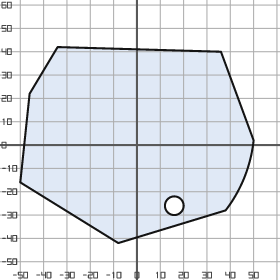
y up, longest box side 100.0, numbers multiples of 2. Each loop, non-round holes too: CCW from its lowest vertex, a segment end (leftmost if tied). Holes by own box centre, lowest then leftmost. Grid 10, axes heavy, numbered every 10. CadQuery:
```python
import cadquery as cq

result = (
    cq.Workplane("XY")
    .moveTo(-8.0, -42.0)
    .lineTo(38.0, -28.0)
    .threePointArc((46.0, -14.0), (50.0, 2.0))
    .lineTo(36.0, 40.0)
    .lineTo(-34.0, 42.0)
    .lineTo(-46.0, 22.0)
    .lineTo(-50.0, -16.0)
    .close()
    .moveTo(16.0, -26.0)
    .circle(4.0)
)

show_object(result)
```